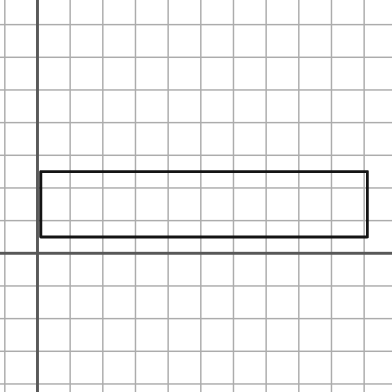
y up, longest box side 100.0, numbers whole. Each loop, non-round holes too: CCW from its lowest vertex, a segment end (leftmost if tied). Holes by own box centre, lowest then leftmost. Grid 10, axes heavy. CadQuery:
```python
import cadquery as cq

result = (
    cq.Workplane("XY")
    .moveTo(1.0, 5.0)
    .lineTo(101.0, 5.0)
    .lineTo(101.0, 25.0)
    .lineTo(1.0, 25.0)
    .close()
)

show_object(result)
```